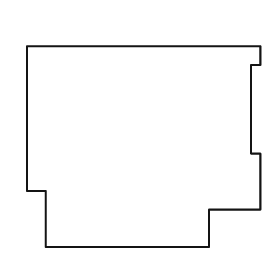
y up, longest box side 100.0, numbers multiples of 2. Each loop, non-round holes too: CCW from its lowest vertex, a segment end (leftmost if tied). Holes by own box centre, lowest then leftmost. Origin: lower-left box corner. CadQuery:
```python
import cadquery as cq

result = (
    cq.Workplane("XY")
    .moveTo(8.0, 0.0)
    .lineTo(78.0, 0.0)
    .lineTo(78.0, 16.0)
    .lineTo(100.0, 16.0)
    .lineTo(100.0, 40.0)
    .lineTo(96.0, 40.0)
    .lineTo(96.0, 78.0)
    .lineTo(100.0, 78.0)
    .lineTo(100.0, 86.0)
    .lineTo(0.0, 86.0)
    .lineTo(0.0, 24.0)
    .lineTo(8.0, 24.0)
    .close()
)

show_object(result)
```